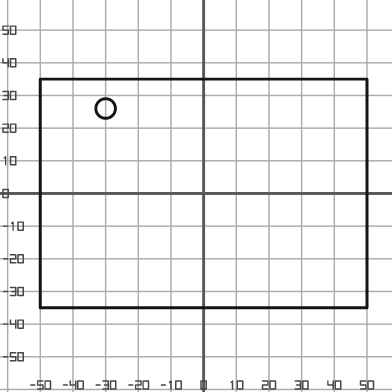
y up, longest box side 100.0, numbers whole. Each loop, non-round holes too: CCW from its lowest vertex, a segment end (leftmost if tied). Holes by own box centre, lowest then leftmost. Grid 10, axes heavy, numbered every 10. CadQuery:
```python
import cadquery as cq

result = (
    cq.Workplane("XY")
    .moveTo(-50.0, -35.0)
    .lineTo(50.0, -35.0)
    .lineTo(50.0, 35.0)
    .lineTo(-50.0, 35.0)
    .close()
    .moveTo(-30.0, 26.0)
    .circle(3.0)
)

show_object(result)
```